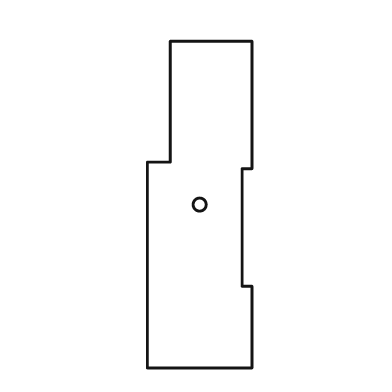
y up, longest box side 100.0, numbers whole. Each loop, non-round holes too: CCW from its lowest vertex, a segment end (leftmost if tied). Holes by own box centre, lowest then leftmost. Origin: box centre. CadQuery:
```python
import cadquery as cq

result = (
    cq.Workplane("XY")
    .moveTo(-16.0, -50.0)
    .lineTo(16.0, -50.0)
    .lineTo(16.0, -25.0)
    .lineTo(13.0, -25.0)
    .lineTo(13.0, 11.0)
    .lineTo(16.0, 11.0)
    .lineTo(16.0, 50.0)
    .lineTo(-9.0, 50.0)
    .lineTo(-9.0, 13.0)
    .lineTo(-16.0, 13.0)
    .close()
    .moveTo(0.0, 0.0)
    .circle(2.0)
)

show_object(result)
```